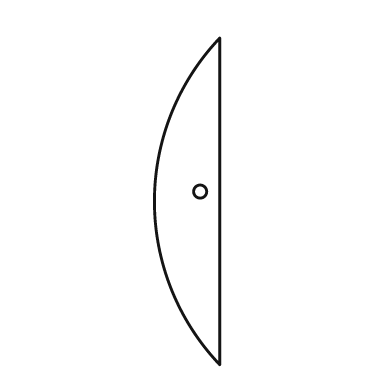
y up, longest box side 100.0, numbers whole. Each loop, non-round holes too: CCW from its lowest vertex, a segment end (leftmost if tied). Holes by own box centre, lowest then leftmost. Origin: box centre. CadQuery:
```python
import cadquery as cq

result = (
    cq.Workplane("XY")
    .moveTo(10.0, -50.0)
    .lineTo(10.0, 50.0)
    .threePointArc((-10.0, 0.0), (10.0, -50.0))
    .close()
    .moveTo(4.0, 3.0)
    .circle(2.0)
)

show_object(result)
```